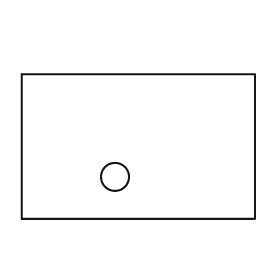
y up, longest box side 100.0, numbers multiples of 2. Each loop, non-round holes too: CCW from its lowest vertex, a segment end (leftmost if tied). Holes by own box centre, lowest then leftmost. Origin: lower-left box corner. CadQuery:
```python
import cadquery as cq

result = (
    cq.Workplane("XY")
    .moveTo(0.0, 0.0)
    .lineTo(100.0, 0.0)
    .lineTo(100.0, 62.0)
    .lineTo(0.0, 62.0)
    .close()
    .moveTo(40.0, 18.0)
    .circle(6.0)
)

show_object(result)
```